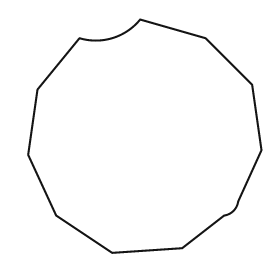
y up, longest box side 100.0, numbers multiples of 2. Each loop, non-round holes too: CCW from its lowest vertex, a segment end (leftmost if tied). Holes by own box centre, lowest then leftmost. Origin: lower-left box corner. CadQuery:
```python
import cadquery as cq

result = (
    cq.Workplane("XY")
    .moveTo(36.0, 0.0)
    .lineTo(66.0, 2.0)
    .lineTo(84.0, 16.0)
    .threePointArc((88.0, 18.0), (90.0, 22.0))
    .lineTo(100.0, 44.0)
    .lineTo(96.0, 72.0)
    .lineTo(76.0, 92.0)
    .lineTo(48.0, 100.0)
    .threePointArc((36.0, 92.0), (22.0, 92.0))
    .lineTo(4.0, 70.0)
    .lineTo(0.0, 42.0)
    .lineTo(12.0, 16.0)
    .close()
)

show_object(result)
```